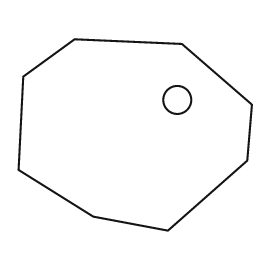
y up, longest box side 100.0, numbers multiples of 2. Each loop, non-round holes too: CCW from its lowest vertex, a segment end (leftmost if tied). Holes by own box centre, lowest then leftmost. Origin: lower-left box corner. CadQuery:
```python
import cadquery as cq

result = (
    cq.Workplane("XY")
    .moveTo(64.0, 0.0)
    .lineTo(98.0, 30.0)
    .lineTo(100.0, 54.0)
    .lineTo(70.0, 80.0)
    .lineTo(24.0, 82.0)
    .lineTo(2.0, 66.0)
    .lineTo(0.0, 26.0)
    .lineTo(32.0, 6.0)
    .close()
    .moveTo(68.0, 56.0)
    .circle(6.0)
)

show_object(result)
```